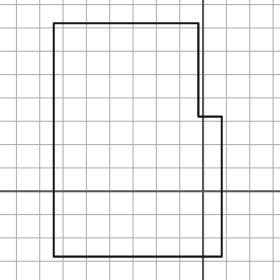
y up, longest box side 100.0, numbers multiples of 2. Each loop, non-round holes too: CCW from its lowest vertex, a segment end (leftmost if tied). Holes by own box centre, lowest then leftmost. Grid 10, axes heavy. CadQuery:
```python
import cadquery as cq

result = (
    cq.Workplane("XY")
    .moveTo(-64.0, -28.0)
    .lineTo(8.0, -28.0)
    .lineTo(8.0, 32.0)
    .lineTo(-2.0, 32.0)
    .lineTo(-2.0, 72.0)
    .lineTo(-64.0, 72.0)
    .close()
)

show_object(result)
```